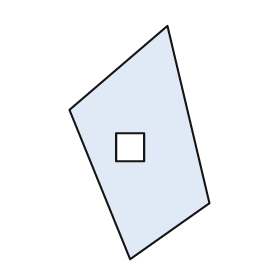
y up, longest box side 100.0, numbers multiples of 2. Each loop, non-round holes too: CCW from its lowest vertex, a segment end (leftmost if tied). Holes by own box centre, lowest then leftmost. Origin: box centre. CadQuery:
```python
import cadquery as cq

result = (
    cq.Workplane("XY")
    .moveTo(-4.0, -50.0)
    .lineTo(30.0, -26.0)
    .lineTo(12.0, 50.0)
    .lineTo(-30.0, 14.0)
    .close()
    .moveTo(-10.0, -8.0)
    .lineTo(2.0, -8.0)
    .lineTo(2.0, 4.0)
    .lineTo(-10.0, 4.0)
    .close()
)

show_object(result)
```